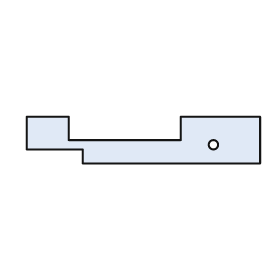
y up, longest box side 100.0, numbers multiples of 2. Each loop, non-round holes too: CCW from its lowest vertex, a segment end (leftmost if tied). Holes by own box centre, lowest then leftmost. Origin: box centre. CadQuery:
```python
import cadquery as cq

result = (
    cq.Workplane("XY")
    .moveTo(-26.0, -10.0)
    .lineTo(50.0, -10.0)
    .lineTo(50.0, 10.0)
    .lineTo(16.0, 10.0)
    .lineTo(16.0, 0.0)
    .lineTo(-32.0, 0.0)
    .lineTo(-32.0, 10.0)
    .lineTo(-50.0, 10.0)
    .lineTo(-50.0, -4.0)
    .lineTo(-26.0, -4.0)
    .close()
    .moveTo(30.0, -2.0)
    .circle(2.0)
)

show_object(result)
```